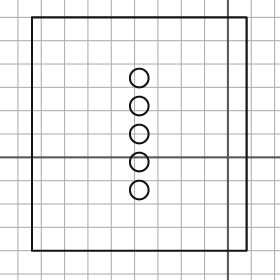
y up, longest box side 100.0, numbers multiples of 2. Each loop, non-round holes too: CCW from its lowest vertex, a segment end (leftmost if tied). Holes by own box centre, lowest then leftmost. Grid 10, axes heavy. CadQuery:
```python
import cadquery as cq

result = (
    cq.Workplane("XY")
    .moveTo(-84.0, -40.0)
    .lineTo(8.0, -40.0)
    .lineTo(8.0, 60.0)
    .lineTo(-84.0, 60.0)
    .close()
    .moveTo(-38.0, -14.0)
    .circle(4.0)
    .moveTo(-38.0, -2.0)
    .circle(4.0)
    .moveTo(-38.0, 10.0)
    .circle(4.0)
    .moveTo(-38.0, 22.0)
    .circle(4.0)
    .moveTo(-38.0, 34.0)
    .circle(4.0)
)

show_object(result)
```